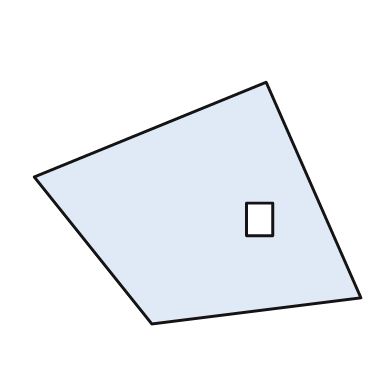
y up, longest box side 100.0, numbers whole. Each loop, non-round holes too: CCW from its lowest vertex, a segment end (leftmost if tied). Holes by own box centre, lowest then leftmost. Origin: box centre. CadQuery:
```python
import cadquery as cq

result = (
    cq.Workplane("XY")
    .moveTo(-14.0, -37.0)
    .lineTo(50.0, -29.0)
    .lineTo(21.0, 37.0)
    .lineTo(-50.0, 8.0)
    .close()
    .moveTo(15.0, -10.0)
    .lineTo(23.0, -10.0)
    .lineTo(23.0, 0.0)
    .lineTo(15.0, 0.0)
    .close()
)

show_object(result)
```